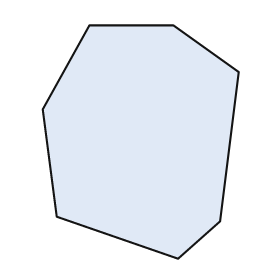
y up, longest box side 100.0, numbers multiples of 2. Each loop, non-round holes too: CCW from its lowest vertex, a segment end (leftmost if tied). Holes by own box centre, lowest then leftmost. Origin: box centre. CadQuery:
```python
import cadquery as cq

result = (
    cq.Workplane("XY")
    .moveTo(16.0, -50.0)
    .lineTo(34.0, -34.0)
    .lineTo(42.0, 30.0)
    .lineTo(14.0, 50.0)
    .lineTo(-22.0, 50.0)
    .lineTo(-42.0, 14.0)
    .lineTo(-36.0, -32.0)
    .close()
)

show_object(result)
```